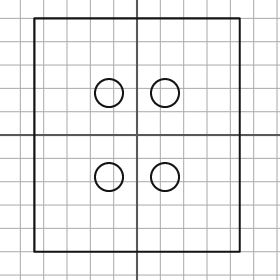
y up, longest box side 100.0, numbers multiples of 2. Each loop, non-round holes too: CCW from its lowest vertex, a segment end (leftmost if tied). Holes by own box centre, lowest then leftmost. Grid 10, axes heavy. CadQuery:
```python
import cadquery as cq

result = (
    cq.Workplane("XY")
    .moveTo(-44.0, -50.0)
    .lineTo(44.0, -50.0)
    .lineTo(44.0, 50.0)
    .lineTo(-44.0, 50.0)
    .close()
    .moveTo(-12.0, -18.0)
    .circle(6.0)
    .moveTo(12.0, -18.0)
    .circle(6.0)
    .moveTo(-12.0, 18.0)
    .circle(6.0)
    .moveTo(12.0, 18.0)
    .circle(6.0)
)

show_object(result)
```